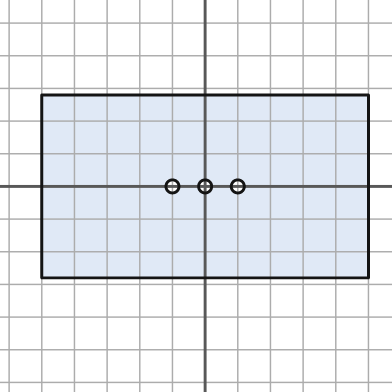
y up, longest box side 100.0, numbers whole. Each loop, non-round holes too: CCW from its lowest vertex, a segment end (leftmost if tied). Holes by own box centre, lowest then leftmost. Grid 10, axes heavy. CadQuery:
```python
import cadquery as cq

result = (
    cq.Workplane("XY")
    .moveTo(-50.0, -28.0)
    .lineTo(50.0, -28.0)
    .lineTo(50.0, 28.0)
    .lineTo(-50.0, 28.0)
    .close()
    .moveTo(-10.0, 0.0)
    .circle(2.0)
    .moveTo(0.0, 0.0)
    .circle(2.0)
    .moveTo(10.0, 0.0)
    .circle(2.0)
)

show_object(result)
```